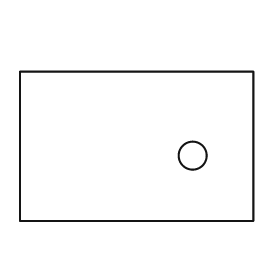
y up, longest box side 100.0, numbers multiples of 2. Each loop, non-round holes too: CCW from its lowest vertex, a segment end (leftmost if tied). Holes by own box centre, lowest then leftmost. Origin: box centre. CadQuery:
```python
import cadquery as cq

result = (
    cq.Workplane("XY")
    .moveTo(-50.0, -32.0)
    .lineTo(50.0, -32.0)
    .lineTo(50.0, 32.0)
    .lineTo(-50.0, 32.0)
    .close()
    .moveTo(24.0, -4.0)
    .circle(6.0)
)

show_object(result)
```